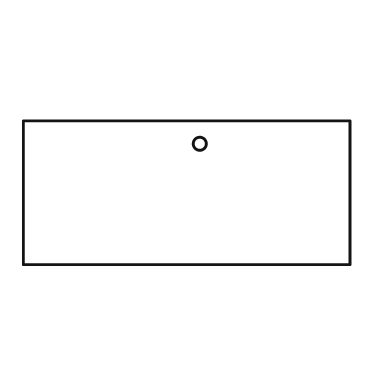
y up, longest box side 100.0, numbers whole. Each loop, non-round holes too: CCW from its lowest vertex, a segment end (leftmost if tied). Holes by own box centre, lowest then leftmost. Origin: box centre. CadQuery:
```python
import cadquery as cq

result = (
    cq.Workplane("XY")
    .moveTo(-50.0, -22.0)
    .lineTo(50.0, -22.0)
    .lineTo(50.0, 22.0)
    .lineTo(-50.0, 22.0)
    .close()
    .moveTo(4.0, 15.0)
    .circle(2.0)
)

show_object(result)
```